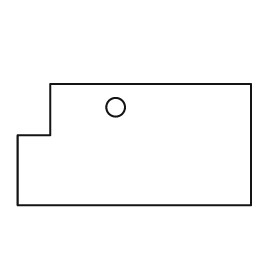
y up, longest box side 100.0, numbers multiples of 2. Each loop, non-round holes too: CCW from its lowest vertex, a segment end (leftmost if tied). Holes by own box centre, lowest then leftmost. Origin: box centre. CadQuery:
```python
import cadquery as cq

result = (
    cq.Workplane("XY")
    .moveTo(-50.0, -26.0)
    .lineTo(50.0, -26.0)
    .lineTo(50.0, 26.0)
    .lineTo(-36.0, 26.0)
    .lineTo(-36.0, 4.0)
    .lineTo(-50.0, 4.0)
    .close()
    .moveTo(-8.0, 16.0)
    .circle(4.0)
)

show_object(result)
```